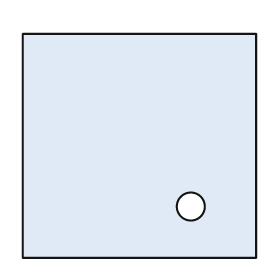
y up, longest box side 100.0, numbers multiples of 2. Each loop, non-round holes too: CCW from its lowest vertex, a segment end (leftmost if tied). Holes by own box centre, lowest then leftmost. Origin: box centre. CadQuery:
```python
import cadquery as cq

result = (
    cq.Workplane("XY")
    .moveTo(-50.0, -48.0)
    .lineTo(50.0, -48.0)
    .lineTo(50.0, 48.0)
    .lineTo(-50.0, 48.0)
    .close()
    .moveTo(22.0, -26.0)
    .circle(6.0)
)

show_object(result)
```